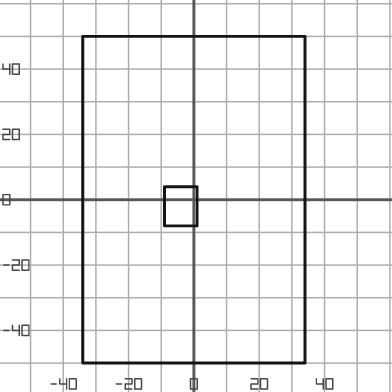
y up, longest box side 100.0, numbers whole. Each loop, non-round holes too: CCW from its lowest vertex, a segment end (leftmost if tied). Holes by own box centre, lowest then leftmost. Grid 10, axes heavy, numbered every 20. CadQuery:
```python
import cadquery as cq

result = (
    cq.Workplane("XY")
    .moveTo(-34.0, -50.0)
    .lineTo(34.0, -50.0)
    .lineTo(34.0, 50.0)
    .lineTo(-34.0, 50.0)
    .close()
    .moveTo(-9.0, -8.0)
    .lineTo(1.0, -8.0)
    .lineTo(1.0, 4.0)
    .lineTo(-9.0, 4.0)
    .close()
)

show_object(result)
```